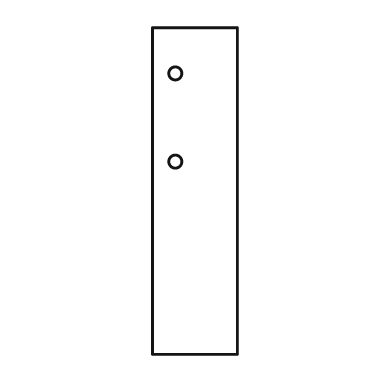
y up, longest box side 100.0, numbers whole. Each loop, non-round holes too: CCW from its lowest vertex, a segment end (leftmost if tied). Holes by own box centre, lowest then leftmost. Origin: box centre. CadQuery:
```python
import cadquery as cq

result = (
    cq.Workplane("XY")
    .moveTo(-13.0, -50.0)
    .lineTo(13.0, -50.0)
    .lineTo(13.0, 50.0)
    .lineTo(-13.0, 50.0)
    .close()
    .moveTo(-6.0, 9.0)
    .circle(2.0)
    .moveTo(-6.0, 36.0)
    .circle(2.0)
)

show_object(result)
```